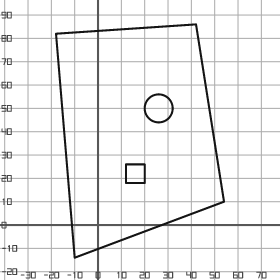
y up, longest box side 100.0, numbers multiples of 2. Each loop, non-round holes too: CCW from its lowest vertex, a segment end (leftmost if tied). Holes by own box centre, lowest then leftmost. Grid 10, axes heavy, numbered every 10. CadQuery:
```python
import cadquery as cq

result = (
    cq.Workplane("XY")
    .moveTo(-10.0, -14.0)
    .lineTo(54.0, 10.0)
    .lineTo(42.0, 86.0)
    .lineTo(-18.0, 82.0)
    .close()
    .moveTo(12.0, 18.0)
    .lineTo(20.0, 18.0)
    .lineTo(20.0, 26.0)
    .lineTo(12.0, 26.0)
    .close()
    .moveTo(26.0, 50.0)
    .circle(6.0)
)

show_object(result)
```